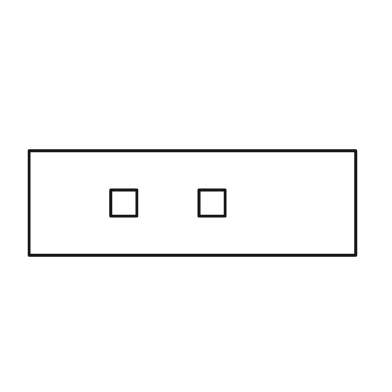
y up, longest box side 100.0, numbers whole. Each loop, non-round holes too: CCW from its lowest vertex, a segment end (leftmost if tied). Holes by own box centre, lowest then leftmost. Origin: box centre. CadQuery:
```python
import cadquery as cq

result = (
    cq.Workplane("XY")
    .moveTo(-50.0, -16.0)
    .lineTo(50.0, -16.0)
    .lineTo(50.0, 16.0)
    .lineTo(-50.0, 16.0)
    .close()
    .moveTo(-25.0, -4.0)
    .lineTo(-17.0, -4.0)
    .lineTo(-17.0, 4.0)
    .lineTo(-25.0, 4.0)
    .close()
    .moveTo(2.0, -4.0)
    .lineTo(10.0, -4.0)
    .lineTo(10.0, 4.0)
    .lineTo(2.0, 4.0)
    .close()
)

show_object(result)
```